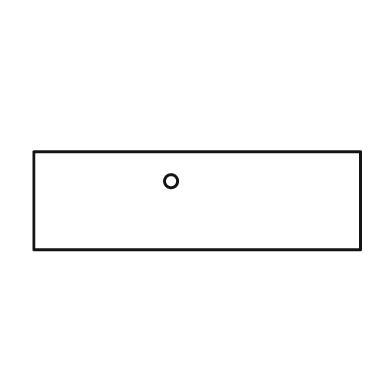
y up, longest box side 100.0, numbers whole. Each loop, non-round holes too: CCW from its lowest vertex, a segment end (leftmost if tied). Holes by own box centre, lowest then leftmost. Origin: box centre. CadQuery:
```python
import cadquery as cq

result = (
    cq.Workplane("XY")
    .moveTo(-50.0, -15.0)
    .lineTo(50.0, -15.0)
    .lineTo(50.0, 15.0)
    .lineTo(-50.0, 15.0)
    .close()
    .moveTo(-8.0, 6.0)
    .circle(2.0)
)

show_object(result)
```